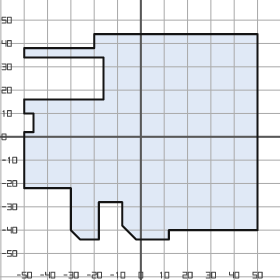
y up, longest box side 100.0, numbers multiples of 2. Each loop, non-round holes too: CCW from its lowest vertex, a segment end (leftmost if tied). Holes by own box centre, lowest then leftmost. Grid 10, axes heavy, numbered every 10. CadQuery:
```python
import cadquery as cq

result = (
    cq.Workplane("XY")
    .moveTo(-26.0, -44.0)
    .lineTo(-18.0, -44.0)
    .lineTo(-18.0, -28.0)
    .lineTo(-8.0, -28.0)
    .lineTo(-8.0, -38.0)
    .lineTo(-2.0, -44.0)
    .lineTo(12.0, -44.0)
    .lineTo(12.0, -40.0)
    .lineTo(50.0, -40.0)
    .lineTo(50.0, 44.0)
    .lineTo(-20.0, 44.0)
    .lineTo(-20.0, 38.0)
    .lineTo(-50.0, 38.0)
    .lineTo(-50.0, 34.0)
    .lineTo(-16.0, 34.0)
    .lineTo(-16.0, 16.0)
    .lineTo(-50.0, 16.0)
    .lineTo(-50.0, 10.0)
    .lineTo(-46.0, 10.0)
    .lineTo(-46.0, 2.0)
    .lineTo(-50.0, 2.0)
    .lineTo(-50.0, -22.0)
    .lineTo(-30.0, -22.0)
    .lineTo(-30.0, -40.0)
    .close()
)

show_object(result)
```